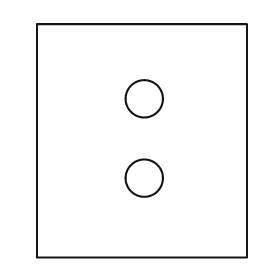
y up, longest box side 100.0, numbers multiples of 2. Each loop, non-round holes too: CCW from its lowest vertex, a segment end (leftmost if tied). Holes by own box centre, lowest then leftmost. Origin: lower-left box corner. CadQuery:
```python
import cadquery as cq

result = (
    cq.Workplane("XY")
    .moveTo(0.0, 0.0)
    .lineTo(90.0, 0.0)
    .lineTo(90.0, 100.0)
    .lineTo(0.0, 100.0)
    .close()
    .moveTo(46.0, 34.0)
    .circle(8.0)
    .moveTo(46.0, 68.0)
    .circle(8.0)
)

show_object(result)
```